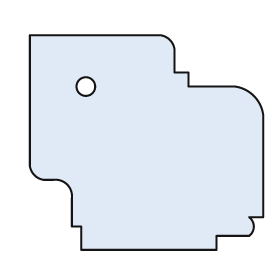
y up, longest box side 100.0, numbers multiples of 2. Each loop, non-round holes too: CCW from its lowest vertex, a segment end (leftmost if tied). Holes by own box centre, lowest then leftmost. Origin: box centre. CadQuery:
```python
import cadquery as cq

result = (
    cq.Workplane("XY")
    .moveTo(-28.0, -46.0)
    .lineTo(30.0, -46.0)
    .lineTo(30.0, -40.0)
    .lineTo(44.0, -40.0)
    .threePointArc((46.0, -36.0), (44.0, -32.0))
    .lineTo(50.0, -32.0)
    .lineTo(50.0, 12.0)
    .threePointArc((46.0, 20.0), (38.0, 24.0))
    .lineTo(18.0, 24.0)
    .lineTo(18.0, 30.0)
    .lineTo(12.0, 30.0)
    .lineTo(12.0, 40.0)
    .threePointArc((10.0, 44.0), (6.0, 46.0))
    .lineTo(-50.0, 46.0)
    .lineTo(-50.0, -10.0)
    .threePointArc((-48.0, -14.0), (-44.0, -16.0))
    .lineTo(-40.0, -16.0)
    .threePointArc((-34.0, -18.0), (-32.0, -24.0))
    .lineTo(-32.0, -36.0)
    .lineTo(-28.0, -36.0)
    .close()
    .moveTo(-26.0, 24.0)
    .circle(4.0)
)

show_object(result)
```